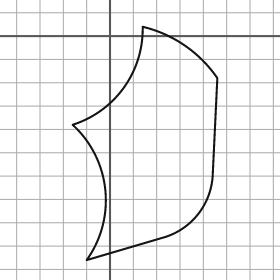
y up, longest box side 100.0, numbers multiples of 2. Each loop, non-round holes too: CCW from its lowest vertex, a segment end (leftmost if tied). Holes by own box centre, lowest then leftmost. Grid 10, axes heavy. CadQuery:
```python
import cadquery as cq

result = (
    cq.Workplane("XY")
    .moveTo(-10.0, -96.0)
    .lineTo(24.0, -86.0)
    .threePointArc((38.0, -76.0), (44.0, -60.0))
    .lineTo(46.0, -18.0)
    .threePointArc((32.0, -4.0), (14.0, 4.0))
    .threePointArc((6.0, -22.0), (-16.0, -38.0))
    .threePointArc((-2.0, -66.0), (-10.0, -96.0))
    .close()
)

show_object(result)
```